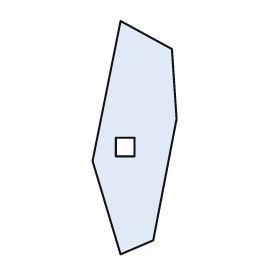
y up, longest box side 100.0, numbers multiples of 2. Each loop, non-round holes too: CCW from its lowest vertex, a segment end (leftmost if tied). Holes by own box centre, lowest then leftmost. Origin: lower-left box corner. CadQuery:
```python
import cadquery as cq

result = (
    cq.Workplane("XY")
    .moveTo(12.0, 0.0)
    .lineTo(26.0, 6.0)
    .lineTo(36.0, 58.0)
    .lineTo(34.0, 88.0)
    .lineTo(12.0, 100.0)
    .lineTo(0.0, 40.0)
    .close()
    .moveTo(10.0, 42.0)
    .lineTo(18.0, 42.0)
    .lineTo(18.0, 50.0)
    .lineTo(10.0, 50.0)
    .close()
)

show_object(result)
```